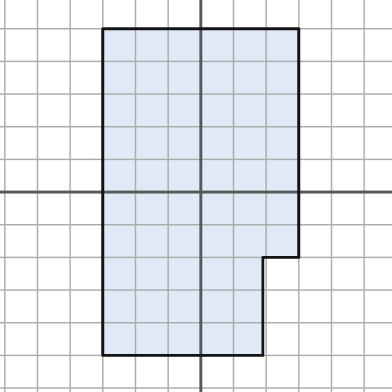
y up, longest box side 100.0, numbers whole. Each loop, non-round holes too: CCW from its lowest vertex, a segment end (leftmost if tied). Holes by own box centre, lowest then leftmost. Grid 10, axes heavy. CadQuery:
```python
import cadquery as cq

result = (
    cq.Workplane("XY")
    .moveTo(-30.0, -50.0)
    .lineTo(19.0, -50.0)
    .lineTo(19.0, -20.0)
    .lineTo(30.0, -20.0)
    .lineTo(30.0, 50.0)
    .lineTo(-30.0, 50.0)
    .close()
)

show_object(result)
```